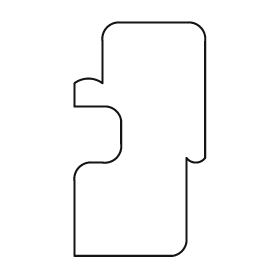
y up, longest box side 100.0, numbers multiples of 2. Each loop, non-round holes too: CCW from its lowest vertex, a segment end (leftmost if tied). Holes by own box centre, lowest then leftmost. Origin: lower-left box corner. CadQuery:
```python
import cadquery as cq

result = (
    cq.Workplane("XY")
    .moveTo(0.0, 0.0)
    .lineTo(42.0, 0.0)
    .threePointArc((46.0, 2.0), (48.0, 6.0))
    .lineTo(48.0, 42.0)
    .threePointArc((52.0, 40.0), (56.0, 42.0))
    .lineTo(56.0, 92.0)
    .threePointArc((54.0, 98.0), (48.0, 100.0))
    .lineTo(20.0, 100.0)
    .threePointArc((14.0, 98.0), (12.0, 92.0))
    .lineTo(12.0, 74.0)
    .threePointArc((6.0, 76.0), (0.0, 74.0))
    .lineTo(0.0, 64.0)
    .lineTo(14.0, 64.0)
    .threePointArc((18.0, 62.0), (20.0, 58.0))
    .lineTo(20.0, 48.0)
    .threePointArc((18.0, 42.0), (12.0, 40.0))
    .lineTo(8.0, 40.0)
    .threePointArc((2.0, 38.0), (0.0, 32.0))
    .close()
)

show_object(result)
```